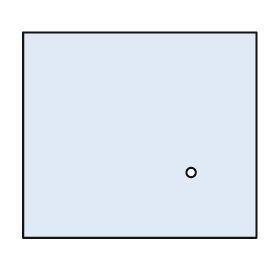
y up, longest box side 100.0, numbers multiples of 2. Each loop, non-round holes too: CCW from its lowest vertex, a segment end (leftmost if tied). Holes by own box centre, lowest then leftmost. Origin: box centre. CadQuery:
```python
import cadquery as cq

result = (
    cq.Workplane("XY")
    .moveTo(-50.0, -44.0)
    .lineTo(50.0, -44.0)
    .lineTo(50.0, 44.0)
    .lineTo(-50.0, 44.0)
    .close()
    .moveTo(22.0, -16.0)
    .circle(2.0)
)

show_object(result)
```